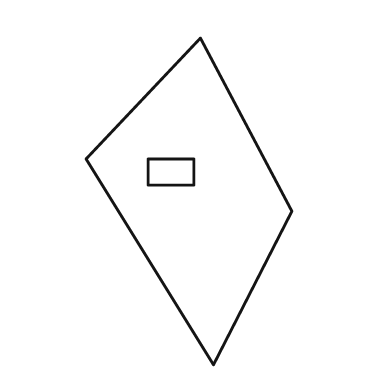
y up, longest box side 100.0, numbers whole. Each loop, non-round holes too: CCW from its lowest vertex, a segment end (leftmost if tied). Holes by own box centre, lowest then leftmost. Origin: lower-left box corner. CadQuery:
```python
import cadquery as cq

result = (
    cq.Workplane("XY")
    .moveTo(39.0, 0.0)
    .lineTo(63.0, 47.0)
    .lineTo(35.0, 100.0)
    .lineTo(0.0, 63.0)
    .close()
    .moveTo(19.0, 55.0)
    .lineTo(33.0, 55.0)
    .lineTo(33.0, 63.0)
    .lineTo(19.0, 63.0)
    .close()
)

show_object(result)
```